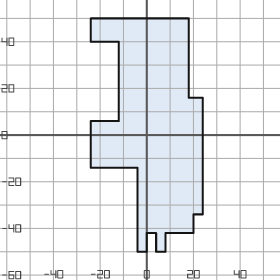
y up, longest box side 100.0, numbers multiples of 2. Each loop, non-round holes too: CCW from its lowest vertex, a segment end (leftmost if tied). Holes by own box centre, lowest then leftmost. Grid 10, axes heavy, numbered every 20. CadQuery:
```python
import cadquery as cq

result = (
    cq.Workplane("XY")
    .moveTo(-4.0, -50.0)
    .lineTo(0.0, -50.0)
    .lineTo(0.0, -42.0)
    .lineTo(4.0, -42.0)
    .lineTo(4.0, -50.0)
    .lineTo(8.0, -50.0)
    .lineTo(8.0, -42.0)
    .lineTo(20.0, -42.0)
    .lineTo(20.0, -34.0)
    .lineTo(24.0, -34.0)
    .lineTo(24.0, 16.0)
    .lineTo(18.0, 16.0)
    .lineTo(18.0, 50.0)
    .lineTo(-24.0, 50.0)
    .lineTo(-24.0, 40.0)
    .lineTo(-12.0, 40.0)
    .lineTo(-12.0, 6.0)
    .lineTo(-24.0, 6.0)
    .lineTo(-24.0, -14.0)
    .lineTo(-4.0, -14.0)
    .close()
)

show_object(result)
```